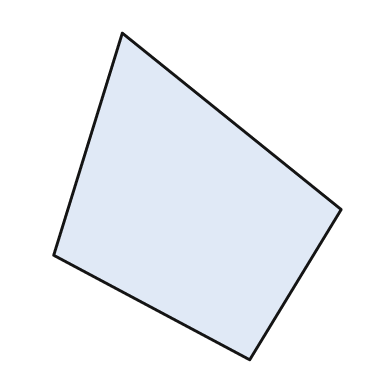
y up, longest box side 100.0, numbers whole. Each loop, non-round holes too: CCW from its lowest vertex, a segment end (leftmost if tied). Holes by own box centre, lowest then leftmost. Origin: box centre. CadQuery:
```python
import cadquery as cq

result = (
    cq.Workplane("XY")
    .moveTo(16.0, -50.0)
    .lineTo(44.0, -4.0)
    .lineTo(-23.0, 50.0)
    .lineTo(-44.0, -18.0)
    .close()
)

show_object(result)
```